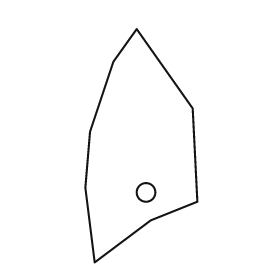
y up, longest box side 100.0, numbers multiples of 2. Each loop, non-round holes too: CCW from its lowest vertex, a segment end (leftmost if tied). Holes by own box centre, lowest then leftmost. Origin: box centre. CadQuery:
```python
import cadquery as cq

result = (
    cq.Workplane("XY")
    .moveTo(-20.0, -50.0)
    .lineTo(4.0, -32.0)
    .lineTo(24.0, -24.0)
    .lineTo(22.0, 16.0)
    .lineTo(-2.0, 50.0)
    .lineTo(-12.0, 36.0)
    .lineTo(-22.0, 6.0)
    .lineTo(-24.0, -18.0)
    .close()
    .moveTo(2.0, -20.0)
    .circle(4.0)
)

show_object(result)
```